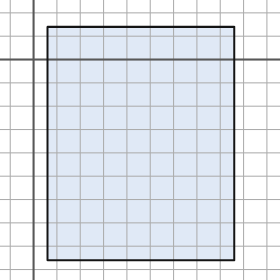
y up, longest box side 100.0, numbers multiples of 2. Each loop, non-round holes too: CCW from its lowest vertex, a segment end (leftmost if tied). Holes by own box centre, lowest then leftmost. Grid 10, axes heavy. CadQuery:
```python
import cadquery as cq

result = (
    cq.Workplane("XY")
    .moveTo(6.0, -86.0)
    .lineTo(86.0, -86.0)
    .lineTo(86.0, 14.0)
    .lineTo(6.0, 14.0)
    .close()
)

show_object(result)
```